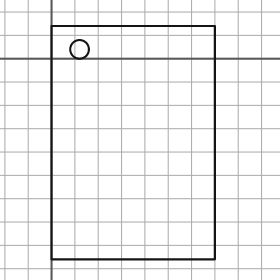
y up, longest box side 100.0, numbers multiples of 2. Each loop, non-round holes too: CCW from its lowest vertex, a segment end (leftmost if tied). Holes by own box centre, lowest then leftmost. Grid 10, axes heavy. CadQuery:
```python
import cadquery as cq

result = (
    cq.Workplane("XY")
    .moveTo(0.0, -86.0)
    .lineTo(70.0, -86.0)
    .lineTo(70.0, 14.0)
    .lineTo(0.0, 14.0)
    .close()
    .moveTo(12.0, 4.0)
    .circle(4.0)
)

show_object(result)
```